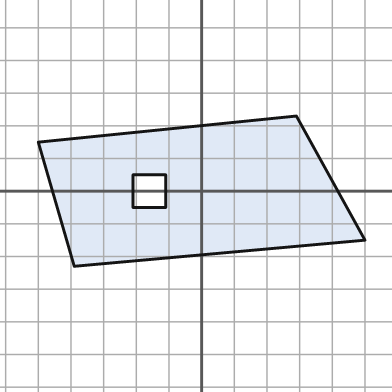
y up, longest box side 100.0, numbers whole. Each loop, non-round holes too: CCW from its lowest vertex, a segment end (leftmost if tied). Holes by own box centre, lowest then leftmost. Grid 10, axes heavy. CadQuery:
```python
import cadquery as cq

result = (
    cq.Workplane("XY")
    .moveTo(-39.0, -23.0)
    .lineTo(50.0, -15.0)
    .lineTo(29.0, 23.0)
    .lineTo(-50.0, 15.0)
    .close()
    .moveTo(-21.0, -5.0)
    .lineTo(-11.0, -5.0)
    .lineTo(-11.0, 5.0)
    .lineTo(-21.0, 5.0)
    .close()
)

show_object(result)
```